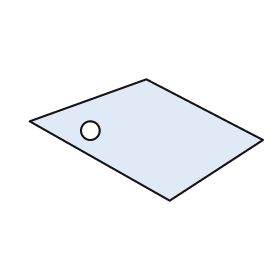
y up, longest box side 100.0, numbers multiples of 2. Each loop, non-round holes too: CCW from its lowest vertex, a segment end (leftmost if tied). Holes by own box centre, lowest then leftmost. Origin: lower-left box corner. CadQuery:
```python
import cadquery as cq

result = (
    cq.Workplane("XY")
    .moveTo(60.0, 0.0)
    .lineTo(100.0, 26.0)
    .lineTo(50.0, 52.0)
    .lineTo(0.0, 34.0)
    .close()
    .moveTo(26.0, 30.0)
    .circle(4.0)
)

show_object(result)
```